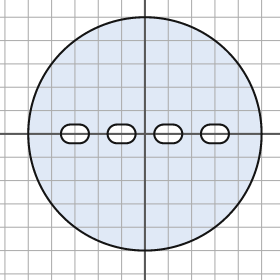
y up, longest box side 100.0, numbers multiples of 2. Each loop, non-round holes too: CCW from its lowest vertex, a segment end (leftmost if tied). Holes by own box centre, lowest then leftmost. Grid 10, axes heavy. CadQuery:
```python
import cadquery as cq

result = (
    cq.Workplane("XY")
    .moveTo(0.0, 0.0)
    .circle(50.0)
    .moveTo(-32.0, -4.0)
    .lineTo(-28.0, -4.0)
    .threePointArc((-24.0, 0.0), (-28.0, 4.0))
    .lineTo(-32.0, 4.0)
    .threePointArc((-36.0, 0.0), (-32.0, -4.0))
    .close()
    .moveTo(-12.0, -4.0)
    .lineTo(-8.0, -4.0)
    .threePointArc((-4.0, 0.0), (-8.0, 4.0))
    .lineTo(-12.0, 4.0)
    .threePointArc((-16.0, 0.0), (-12.0, -4.0))
    .close()
    .moveTo(8.0, -4.0)
    .lineTo(12.0, -4.0)
    .threePointArc((16.0, 0.0), (12.0, 4.0))
    .lineTo(8.0, 4.0)
    .threePointArc((4.0, 0.0), (8.0, -4.0))
    .close()
    .moveTo(28.0, -4.0)
    .lineTo(32.0, -4.0)
    .threePointArc((36.0, 0.0), (32.0, 4.0))
    .lineTo(28.0, 4.0)
    .threePointArc((24.0, 0.0), (28.0, -4.0))
    .close()
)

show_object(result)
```